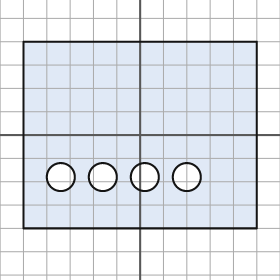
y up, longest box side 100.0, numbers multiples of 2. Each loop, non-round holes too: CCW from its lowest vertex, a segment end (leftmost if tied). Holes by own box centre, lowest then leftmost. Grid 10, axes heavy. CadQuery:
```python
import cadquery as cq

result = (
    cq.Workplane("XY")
    .moveTo(-50.0, -40.0)
    .lineTo(50.0, -40.0)
    .lineTo(50.0, 40.0)
    .lineTo(-50.0, 40.0)
    .close()
    .moveTo(-34.0, -18.0)
    .circle(6.0)
    .moveTo(-16.0, -18.0)
    .circle(6.0)
    .moveTo(2.0, -18.0)
    .circle(6.0)
    .moveTo(20.0, -18.0)
    .circle(6.0)
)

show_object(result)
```